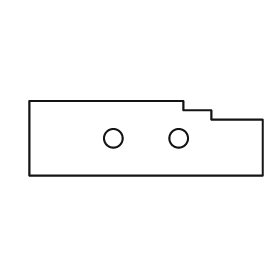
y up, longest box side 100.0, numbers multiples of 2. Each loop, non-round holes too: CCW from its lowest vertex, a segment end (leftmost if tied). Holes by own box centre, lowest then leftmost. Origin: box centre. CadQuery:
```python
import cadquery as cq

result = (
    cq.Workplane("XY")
    .moveTo(-50.0, -16.0)
    .lineTo(50.0, -16.0)
    .lineTo(50.0, 8.0)
    .lineTo(28.0, 8.0)
    .lineTo(28.0, 12.0)
    .lineTo(16.0, 12.0)
    .lineTo(16.0, 16.0)
    .lineTo(-50.0, 16.0)
    .close()
    .moveTo(-14.0, 0.0)
    .circle(4.0)
    .moveTo(14.0, 0.0)
    .circle(4.0)
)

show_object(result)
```